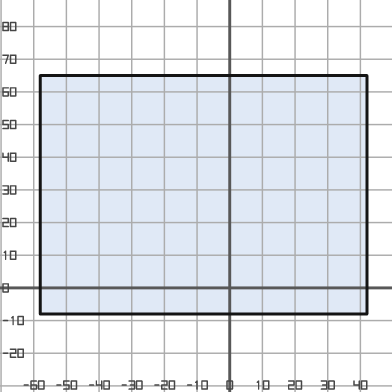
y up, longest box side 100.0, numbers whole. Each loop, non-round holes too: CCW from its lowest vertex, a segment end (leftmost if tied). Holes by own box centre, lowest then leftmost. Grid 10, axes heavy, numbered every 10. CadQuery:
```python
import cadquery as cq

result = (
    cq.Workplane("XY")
    .moveTo(-58.0, -8.0)
    .lineTo(42.0, -8.0)
    .lineTo(42.0, 65.0)
    .lineTo(-58.0, 65.0)
    .close()
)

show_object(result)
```